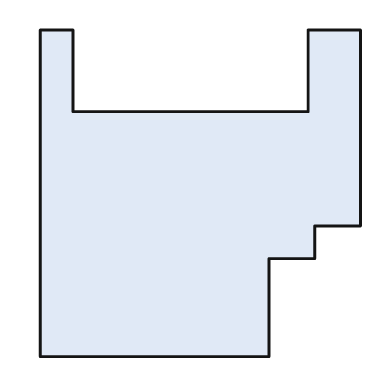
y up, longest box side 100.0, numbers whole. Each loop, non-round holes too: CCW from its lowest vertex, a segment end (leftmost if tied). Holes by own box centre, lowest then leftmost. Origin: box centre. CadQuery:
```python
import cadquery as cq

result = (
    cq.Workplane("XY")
    .moveTo(-49.0, -50.0)
    .lineTo(21.0, -50.0)
    .lineTo(21.0, -20.0)
    .lineTo(35.0, -20.0)
    .lineTo(35.0, -10.0)
    .lineTo(49.0, -10.0)
    .lineTo(49.0, 50.0)
    .lineTo(33.0, 50.0)
    .lineTo(33.0, 25.0)
    .lineTo(-39.0, 25.0)
    .lineTo(-39.0, 50.0)
    .lineTo(-49.0, 50.0)
    .close()
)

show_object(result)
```